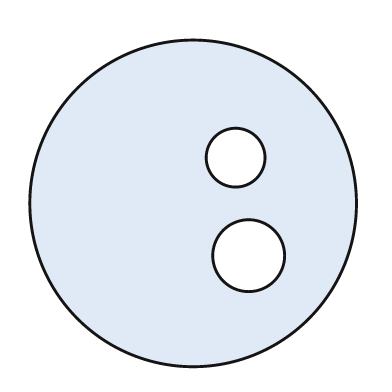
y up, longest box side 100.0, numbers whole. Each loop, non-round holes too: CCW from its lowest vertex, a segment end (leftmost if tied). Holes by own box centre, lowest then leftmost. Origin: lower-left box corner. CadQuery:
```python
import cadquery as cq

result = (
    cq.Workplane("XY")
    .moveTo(50.0, 50.0)
    .circle(50.0)
    .moveTo(67.0, 34.0)
    .circle(11.0)
    .moveTo(63.0, 64.0)
    .circle(9.0)
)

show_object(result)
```